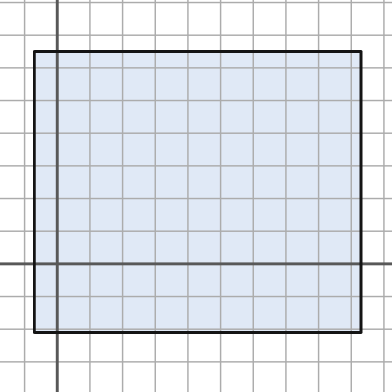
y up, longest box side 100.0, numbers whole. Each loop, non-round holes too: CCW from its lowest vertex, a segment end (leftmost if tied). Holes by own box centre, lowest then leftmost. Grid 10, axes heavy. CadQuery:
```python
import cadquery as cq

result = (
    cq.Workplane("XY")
    .moveTo(-7.0, -21.0)
    .lineTo(93.0, -21.0)
    .lineTo(93.0, 65.0)
    .lineTo(-7.0, 65.0)
    .close()
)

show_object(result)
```